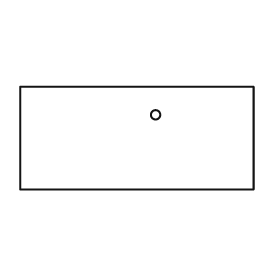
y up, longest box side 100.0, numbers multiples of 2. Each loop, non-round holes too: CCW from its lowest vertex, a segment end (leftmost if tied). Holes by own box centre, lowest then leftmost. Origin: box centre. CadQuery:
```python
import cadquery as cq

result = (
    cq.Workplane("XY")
    .moveTo(-50.0, -22.0)
    .lineTo(50.0, -22.0)
    .lineTo(50.0, 22.0)
    .lineTo(-50.0, 22.0)
    .close()
    .moveTo(8.0, 10.0)
    .circle(2.0)
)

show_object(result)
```